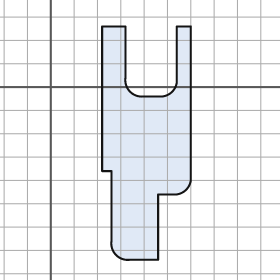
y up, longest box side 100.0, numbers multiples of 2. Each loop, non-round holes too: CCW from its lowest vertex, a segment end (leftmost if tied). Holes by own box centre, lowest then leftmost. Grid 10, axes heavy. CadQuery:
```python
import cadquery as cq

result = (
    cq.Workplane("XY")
    .moveTo(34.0, -74.0)
    .lineTo(46.0, -74.0)
    .lineTo(46.0, -46.0)
    .lineTo(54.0, -46.0)
    .threePointArc((58.0, -44.0), (60.0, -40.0))
    .lineTo(60.0, 26.0)
    .lineTo(54.0, 26.0)
    .lineTo(54.0, 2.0)
    .threePointArc((52.0, -2.0), (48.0, -4.0))
    .lineTo(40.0, -4.0)
    .threePointArc((34.0, -2.0), (32.0, 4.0))
    .lineTo(32.0, 26.0)
    .lineTo(22.0, 26.0)
    .lineTo(22.0, -36.0)
    .lineTo(26.0, -36.0)
    .lineTo(26.0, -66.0)
    .threePointArc((28.0, -72.0), (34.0, -74.0))
    .close()
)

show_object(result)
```